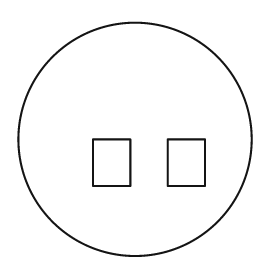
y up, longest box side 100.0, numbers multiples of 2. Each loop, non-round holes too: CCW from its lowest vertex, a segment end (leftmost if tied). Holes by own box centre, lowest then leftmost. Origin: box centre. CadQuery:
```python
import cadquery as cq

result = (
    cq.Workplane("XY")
    .moveTo(0.0, 0.0)
    .circle(50.0)
    .moveTo(-18.0, -20.0)
    .lineTo(-2.0, -20.0)
    .lineTo(-2.0, 0.0)
    .lineTo(-18.0, 0.0)
    .close()
    .moveTo(14.0, -20.0)
    .lineTo(30.0, -20.0)
    .lineTo(30.0, 0.0)
    .lineTo(14.0, 0.0)
    .close()
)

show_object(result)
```